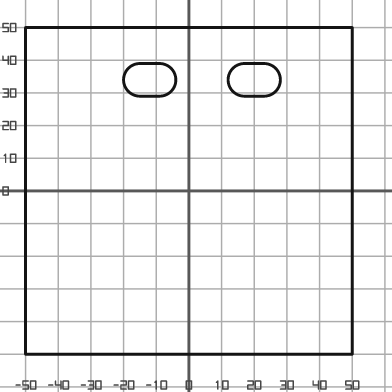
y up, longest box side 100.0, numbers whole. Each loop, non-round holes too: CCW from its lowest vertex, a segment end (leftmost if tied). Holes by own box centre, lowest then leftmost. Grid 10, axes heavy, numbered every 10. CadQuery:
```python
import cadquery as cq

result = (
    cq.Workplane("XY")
    .moveTo(-50.0, -50.0)
    .lineTo(50.0, -50.0)
    .lineTo(50.0, 50.0)
    .lineTo(-50.0, 50.0)
    .close()
    .moveTo(-15.0, 29.0)
    .lineTo(-9.0, 29.0)
    .threePointArc((-4.0, 34.0), (-9.0, 39.0))
    .lineTo(-15.0, 39.0)
    .threePointArc((-20.0, 34.0), (-15.0, 29.0))
    .close()
    .moveTo(17.0, 29.0)
    .lineTo(23.0, 29.0)
    .threePointArc((28.0, 34.0), (23.0, 39.0))
    .lineTo(17.0, 39.0)
    .threePointArc((12.0, 34.0), (17.0, 29.0))
    .close()
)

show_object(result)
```